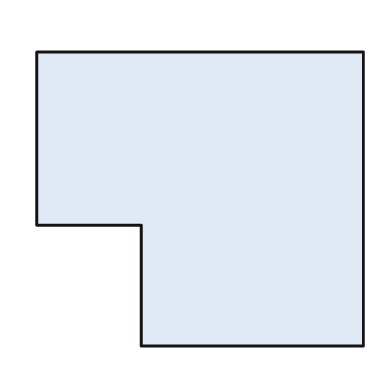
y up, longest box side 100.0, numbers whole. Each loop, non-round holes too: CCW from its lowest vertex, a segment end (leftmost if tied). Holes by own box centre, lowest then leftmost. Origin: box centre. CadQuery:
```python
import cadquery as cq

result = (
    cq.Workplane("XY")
    .moveTo(-18.0, -45.0)
    .lineTo(50.0, -45.0)
    .lineTo(50.0, 45.0)
    .lineTo(-50.0, 45.0)
    .lineTo(-50.0, -8.0)
    .lineTo(-18.0, -8.0)
    .close()
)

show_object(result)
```